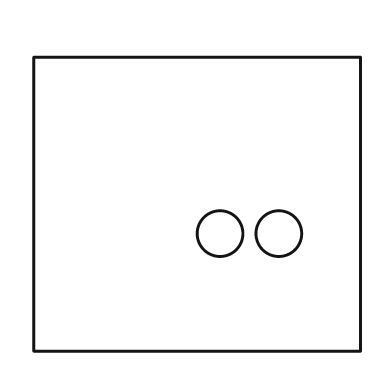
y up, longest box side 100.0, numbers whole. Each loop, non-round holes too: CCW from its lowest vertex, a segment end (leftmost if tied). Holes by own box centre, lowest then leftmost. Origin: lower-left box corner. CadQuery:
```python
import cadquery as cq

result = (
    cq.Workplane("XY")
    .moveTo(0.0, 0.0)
    .lineTo(100.0, 0.0)
    .lineTo(100.0, 90.0)
    .lineTo(0.0, 90.0)
    .close()
    .moveTo(57.0, 36.0)
    .circle(7.0)
    .moveTo(75.0, 36.0)
    .circle(7.0)
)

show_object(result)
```